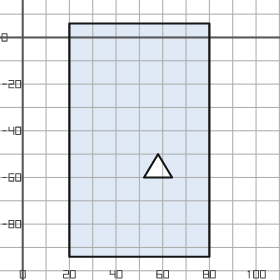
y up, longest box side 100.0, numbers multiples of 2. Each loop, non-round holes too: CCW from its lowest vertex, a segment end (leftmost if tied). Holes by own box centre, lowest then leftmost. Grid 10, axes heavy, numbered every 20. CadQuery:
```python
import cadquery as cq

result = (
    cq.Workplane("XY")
    .moveTo(20.0, -94.0)
    .lineTo(80.0, -94.0)
    .lineTo(80.0, 6.0)
    .lineTo(20.0, 6.0)
    .close()
    .moveTo(52.0, -60.0)
    .lineTo(64.0, -60.0)
    .lineTo(58.0, -50.0)
    .close()
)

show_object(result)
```